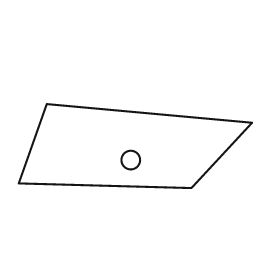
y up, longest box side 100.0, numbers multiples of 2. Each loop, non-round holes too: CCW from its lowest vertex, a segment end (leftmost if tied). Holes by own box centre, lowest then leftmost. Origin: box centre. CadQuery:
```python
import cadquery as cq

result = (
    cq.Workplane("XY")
    .moveTo(24.0, -18.0)
    .lineTo(50.0, 10.0)
    .lineTo(-38.0, 18.0)
    .lineTo(-50.0, -16.0)
    .close()
    .moveTo(-2.0, -6.0)
    .circle(4.0)
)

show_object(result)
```